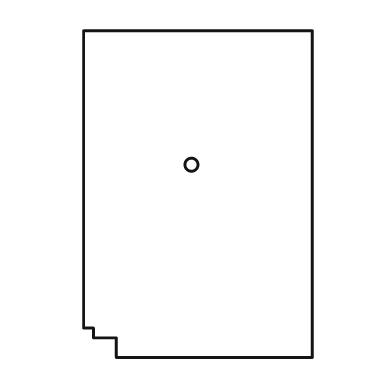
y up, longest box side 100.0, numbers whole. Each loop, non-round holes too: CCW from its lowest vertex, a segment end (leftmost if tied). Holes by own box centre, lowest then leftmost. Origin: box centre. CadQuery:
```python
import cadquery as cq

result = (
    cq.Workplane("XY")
    .moveTo(-25.0, -50.0)
    .lineTo(35.0, -50.0)
    .lineTo(35.0, 50.0)
    .lineTo(-35.0, 50.0)
    .lineTo(-35.0, -41.0)
    .lineTo(-32.0, -41.0)
    .lineTo(-32.0, -44.0)
    .lineTo(-25.0, -44.0)
    .close()
    .moveTo(-2.0, 9.0)
    .circle(2.0)
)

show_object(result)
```